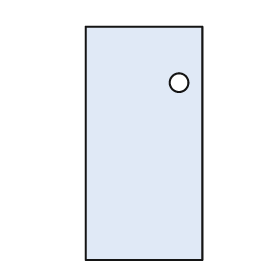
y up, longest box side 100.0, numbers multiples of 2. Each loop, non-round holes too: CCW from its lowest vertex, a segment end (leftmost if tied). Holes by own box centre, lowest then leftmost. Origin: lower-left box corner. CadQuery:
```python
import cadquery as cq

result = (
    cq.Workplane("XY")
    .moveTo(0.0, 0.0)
    .lineTo(50.0, 0.0)
    .lineTo(50.0, 100.0)
    .lineTo(0.0, 100.0)
    .close()
    .moveTo(40.0, 76.0)
    .circle(4.0)
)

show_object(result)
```